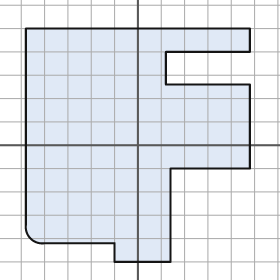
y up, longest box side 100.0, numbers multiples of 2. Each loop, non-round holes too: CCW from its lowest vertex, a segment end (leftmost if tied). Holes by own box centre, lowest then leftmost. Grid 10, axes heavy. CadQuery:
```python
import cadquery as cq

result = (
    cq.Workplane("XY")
    .moveTo(-10.0, -50.0)
    .lineTo(14.0, -50.0)
    .lineTo(14.0, -10.0)
    .lineTo(48.0, -10.0)
    .lineTo(48.0, 26.0)
    .lineTo(12.0, 26.0)
    .lineTo(12.0, 40.0)
    .lineTo(48.0, 40.0)
    .lineTo(48.0, 50.0)
    .lineTo(-48.0, 50.0)
    .lineTo(-48.0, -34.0)
    .threePointArc((-46.0, -40.0), (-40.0, -42.0))
    .lineTo(-10.0, -42.0)
    .close()
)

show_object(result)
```